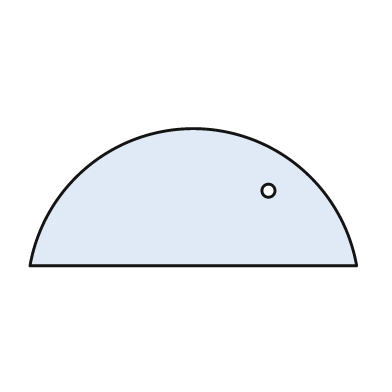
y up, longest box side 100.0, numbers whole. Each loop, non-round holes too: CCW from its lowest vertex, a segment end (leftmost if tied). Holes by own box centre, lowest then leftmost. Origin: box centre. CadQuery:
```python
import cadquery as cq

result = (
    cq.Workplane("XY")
    .moveTo(-50.0, -21.0)
    .lineTo(50.0, -21.0)
    .threePointArc((0.0, 21.0), (-50.0, -21.0))
    .close()
    .moveTo(23.0, 2.0)
    .circle(2.0)
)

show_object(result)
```